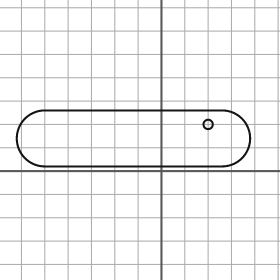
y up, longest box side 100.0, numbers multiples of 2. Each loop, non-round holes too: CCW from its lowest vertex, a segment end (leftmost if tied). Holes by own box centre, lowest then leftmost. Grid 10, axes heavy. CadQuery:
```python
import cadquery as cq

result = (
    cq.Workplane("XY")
    .moveTo(-50.0, 2.0)
    .lineTo(26.0, 2.0)
    .threePointArc((38.0, 14.0), (26.0, 26.0))
    .lineTo(-50.0, 26.0)
    .threePointArc((-62.0, 14.0), (-50.0, 2.0))
    .close()
    .moveTo(20.0, 20.0)
    .circle(2.0)
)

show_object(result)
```